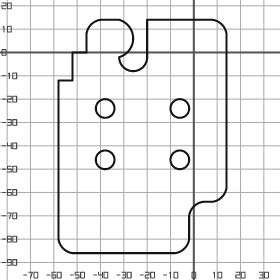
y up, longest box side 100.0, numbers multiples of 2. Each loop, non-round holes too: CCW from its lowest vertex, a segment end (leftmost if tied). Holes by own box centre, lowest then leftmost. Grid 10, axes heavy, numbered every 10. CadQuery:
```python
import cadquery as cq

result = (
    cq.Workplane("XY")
    .moveTo(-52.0, -86.0)
    .lineTo(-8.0, -86.0)
    .threePointArc((-4.0, -84.0), (-2.0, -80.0))
    .lineTo(-2.0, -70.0)
    .threePointArc((0.0, -66.0), (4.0, -64.0))
    .lineTo(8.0, -64.0)
    .threePointArc((12.0, -62.0), (14.0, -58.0))
    .lineTo(14.0, 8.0)
    .threePointArc((12.0, 12.0), (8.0, 14.0))
    .lineTo(-20.0, 14.0)
    .lineTo(-20.0, -2.0)
    .threePointArc((-26.0, -8.0), (-32.0, -2.0))
    .threePointArc((-26.0, 6.0), (-32.0, 14.0))
    .lineTo(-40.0, 14.0)
    .threePointArc((-44.0, 12.0), (-46.0, 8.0))
    .lineTo(-46.0, 0.0)
    .lineTo(-52.0, 0.0)
    .lineTo(-52.0, -12.0)
    .lineTo(-58.0, -12.0)
    .lineTo(-58.0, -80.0)
    .threePointArc((-56.0, -84.0), (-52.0, -86.0))
    .close()
    .moveTo(-38.0, -46.0)
    .circle(4.0)
    .moveTo(-6.0, -46.0)
    .circle(4.0)
    .moveTo(-38.0, -24.0)
    .circle(4.0)
    .moveTo(-6.0, -24.0)
    .circle(4.0)
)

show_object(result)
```